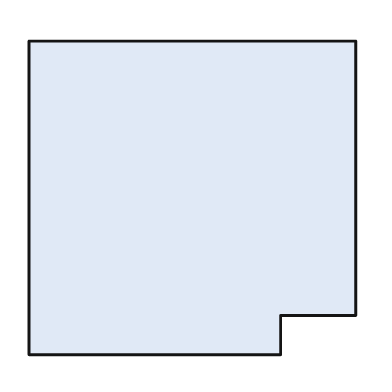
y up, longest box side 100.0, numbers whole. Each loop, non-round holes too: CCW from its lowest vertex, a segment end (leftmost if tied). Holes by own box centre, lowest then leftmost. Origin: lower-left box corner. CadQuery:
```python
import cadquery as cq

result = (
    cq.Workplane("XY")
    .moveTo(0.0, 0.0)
    .lineTo(77.0, 0.0)
    .lineTo(77.0, 12.0)
    .lineTo(100.0, 12.0)
    .lineTo(100.0, 96.0)
    .lineTo(0.0, 96.0)
    .close()
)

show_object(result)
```